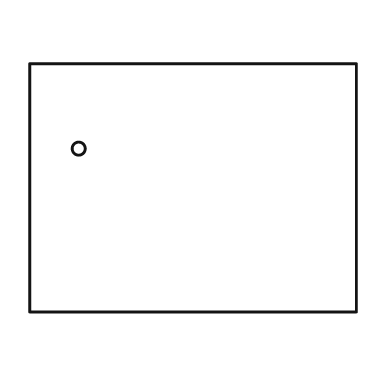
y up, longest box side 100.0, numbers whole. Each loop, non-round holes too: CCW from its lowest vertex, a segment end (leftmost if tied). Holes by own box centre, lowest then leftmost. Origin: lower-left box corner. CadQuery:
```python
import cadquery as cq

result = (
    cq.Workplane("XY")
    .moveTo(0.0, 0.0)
    .lineTo(100.0, 0.0)
    .lineTo(100.0, 76.0)
    .lineTo(0.0, 76.0)
    .close()
    .moveTo(15.0, 50.0)
    .circle(2.0)
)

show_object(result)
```